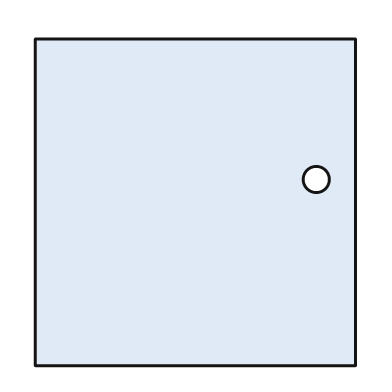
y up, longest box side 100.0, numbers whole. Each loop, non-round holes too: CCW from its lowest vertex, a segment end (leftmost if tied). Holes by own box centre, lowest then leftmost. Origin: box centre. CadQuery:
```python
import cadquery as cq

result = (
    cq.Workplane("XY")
    .moveTo(-49.0, -50.0)
    .lineTo(49.0, -50.0)
    .lineTo(49.0, 50.0)
    .lineTo(-49.0, 50.0)
    .close()
    .moveTo(37.0, 7.0)
    .circle(4.0)
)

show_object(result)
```